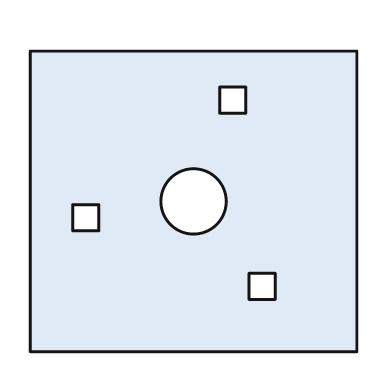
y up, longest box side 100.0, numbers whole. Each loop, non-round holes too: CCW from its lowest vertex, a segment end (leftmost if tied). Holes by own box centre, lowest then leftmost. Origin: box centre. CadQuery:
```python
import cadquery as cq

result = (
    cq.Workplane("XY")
    .moveTo(-50.0, -46.0)
    .lineTo(50.0, -46.0)
    .lineTo(50.0, 46.0)
    .lineTo(-50.0, 46.0)
    .close()
    .moveTo(17.0, -30.0)
    .lineTo(25.0, -30.0)
    .lineTo(25.0, -22.0)
    .lineTo(17.0, -22.0)
    .close()
    .moveTo(-37.0, -9.0)
    .lineTo(-29.0, -9.0)
    .lineTo(-29.0, -1.0)
    .lineTo(-37.0, -1.0)
    .close()
    .moveTo(0.0, 0.0)
    .circle(10.0)
    .moveTo(8.0, 27.0)
    .lineTo(16.0, 27.0)
    .lineTo(16.0, 35.0)
    .lineTo(8.0, 35.0)
    .close()
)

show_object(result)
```